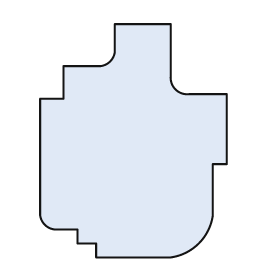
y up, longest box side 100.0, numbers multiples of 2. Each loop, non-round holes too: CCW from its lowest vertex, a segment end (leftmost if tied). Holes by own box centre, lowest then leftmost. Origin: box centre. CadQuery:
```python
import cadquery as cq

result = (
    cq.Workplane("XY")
    .moveTo(-16.0, -50.0)
    .lineTo(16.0, -50.0)
    .threePointArc((28.0, -44.0), (34.0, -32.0))
    .lineTo(34.0, -10.0)
    .lineTo(40.0, -10.0)
    .lineTo(40.0, 20.0)
    .lineTo(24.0, 20.0)
    .threePointArc((18.0, 22.0), (16.0, 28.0))
    .lineTo(16.0, 50.0)
    .lineTo(-8.0, 50.0)
    .lineTo(-8.0, 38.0)
    .threePointArc((-10.0, 34.0), (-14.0, 32.0))
    .lineTo(-30.0, 32.0)
    .lineTo(-30.0, 18.0)
    .lineTo(-40.0, 18.0)
    .lineTo(-40.0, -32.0)
    .threePointArc((-38.0, -36.0), (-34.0, -38.0))
    .lineTo(-24.0, -38.0)
    .lineTo(-24.0, -44.0)
    .lineTo(-16.0, -44.0)
    .close()
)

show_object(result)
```